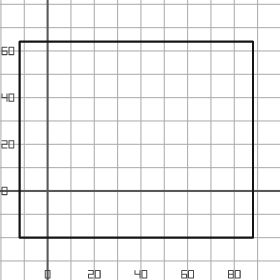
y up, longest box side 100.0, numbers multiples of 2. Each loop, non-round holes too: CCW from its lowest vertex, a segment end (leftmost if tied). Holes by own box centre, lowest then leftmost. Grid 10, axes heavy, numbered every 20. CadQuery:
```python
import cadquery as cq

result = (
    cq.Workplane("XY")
    .moveTo(-12.0, -20.0)
    .lineTo(88.0, -20.0)
    .lineTo(88.0, 64.0)
    .lineTo(-12.0, 64.0)
    .close()
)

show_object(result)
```